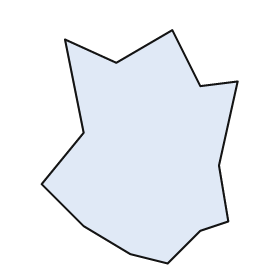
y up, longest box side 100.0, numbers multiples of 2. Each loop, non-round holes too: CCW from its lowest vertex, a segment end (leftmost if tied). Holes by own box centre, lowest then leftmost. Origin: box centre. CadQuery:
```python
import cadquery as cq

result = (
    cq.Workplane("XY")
    .moveTo(12.0, -50.0)
    .lineTo(26.0, -36.0)
    .lineTo(38.0, -32.0)
    .lineTo(34.0, -8.0)
    .lineTo(42.0, 28.0)
    .lineTo(26.0, 26.0)
    .lineTo(14.0, 50.0)
    .lineTo(-10.0, 36.0)
    .lineTo(-32.0, 46.0)
    .lineTo(-24.0, 6.0)
    .lineTo(-42.0, -16.0)
    .lineTo(-24.0, -34.0)
    .lineTo(-4.0, -46.0)
    .close()
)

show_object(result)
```